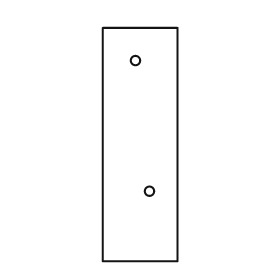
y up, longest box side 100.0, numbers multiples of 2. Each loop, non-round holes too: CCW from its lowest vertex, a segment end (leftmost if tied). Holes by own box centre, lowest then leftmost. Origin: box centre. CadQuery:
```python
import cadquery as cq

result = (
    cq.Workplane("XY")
    .moveTo(-16.0, -50.0)
    .lineTo(16.0, -50.0)
    .lineTo(16.0, 50.0)
    .lineTo(-16.0, 50.0)
    .close()
    .moveTo(4.0, -20.0)
    .circle(2.0)
    .moveTo(-2.0, 36.0)
    .circle(2.0)
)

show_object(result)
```